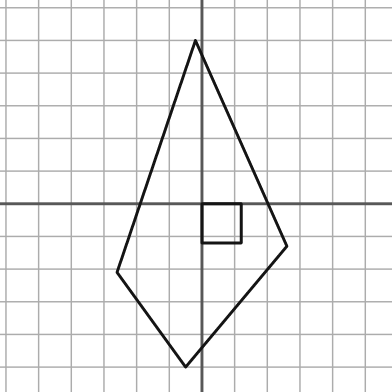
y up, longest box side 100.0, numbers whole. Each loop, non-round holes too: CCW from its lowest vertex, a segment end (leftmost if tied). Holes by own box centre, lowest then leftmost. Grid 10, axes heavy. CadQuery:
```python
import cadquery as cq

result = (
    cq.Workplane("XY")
    .moveTo(-5.0, -50.0)
    .lineTo(26.0, -13.0)
    .lineTo(-2.0, 50.0)
    .lineTo(-26.0, -21.0)
    .close()
    .moveTo(0.0, -12.0)
    .lineTo(12.0, -12.0)
    .lineTo(12.0, 0.0)
    .lineTo(0.0, 0.0)
    .close()
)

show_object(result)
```